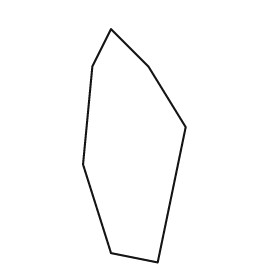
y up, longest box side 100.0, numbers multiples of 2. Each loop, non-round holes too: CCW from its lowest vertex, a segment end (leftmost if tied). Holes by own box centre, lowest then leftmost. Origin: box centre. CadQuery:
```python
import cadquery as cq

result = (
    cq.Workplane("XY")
    .moveTo(10.0, -50.0)
    .lineTo(22.0, 8.0)
    .lineTo(6.0, 34.0)
    .lineTo(-10.0, 50.0)
    .lineTo(-18.0, 34.0)
    .lineTo(-22.0, -8.0)
    .lineTo(-10.0, -46.0)
    .close()
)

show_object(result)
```